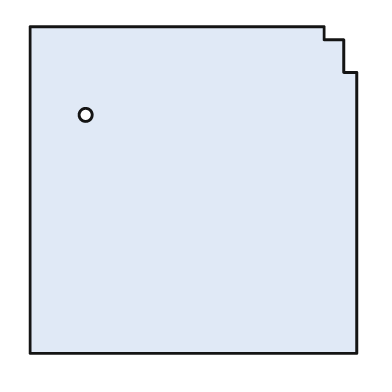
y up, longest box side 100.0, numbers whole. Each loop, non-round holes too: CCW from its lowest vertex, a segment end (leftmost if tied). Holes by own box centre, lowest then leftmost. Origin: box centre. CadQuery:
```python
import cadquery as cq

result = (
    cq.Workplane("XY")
    .moveTo(-50.0, -50.0)
    .lineTo(50.0, -50.0)
    .lineTo(50.0, 36.0)
    .lineTo(46.0, 36.0)
    .lineTo(46.0, 46.0)
    .lineTo(40.0, 46.0)
    .lineTo(40.0, 50.0)
    .lineTo(-50.0, 50.0)
    .close()
    .moveTo(-33.0, 23.0)
    .circle(2.0)
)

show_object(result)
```